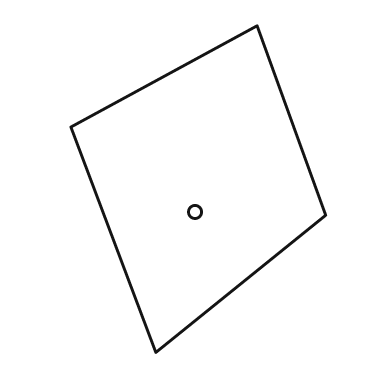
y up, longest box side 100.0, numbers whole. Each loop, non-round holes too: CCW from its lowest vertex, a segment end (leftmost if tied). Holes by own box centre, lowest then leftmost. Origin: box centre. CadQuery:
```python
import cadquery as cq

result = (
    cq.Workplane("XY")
    .moveTo(-13.0, -50.0)
    .lineTo(39.0, -8.0)
    .lineTo(18.0, 50.0)
    .lineTo(-39.0, 19.0)
    .close()
    .moveTo(-1.0, -7.0)
    .circle(2.0)
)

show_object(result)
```